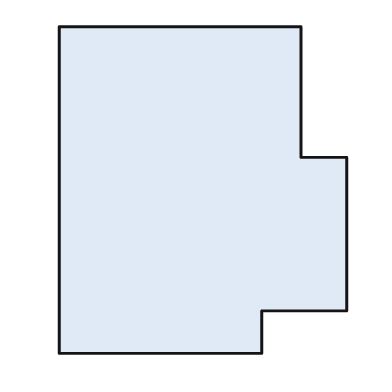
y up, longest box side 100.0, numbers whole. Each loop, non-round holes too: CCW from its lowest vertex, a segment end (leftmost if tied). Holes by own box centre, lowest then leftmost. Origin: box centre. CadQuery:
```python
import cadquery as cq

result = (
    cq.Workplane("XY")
    .moveTo(-44.0, -50.0)
    .lineTo(18.0, -50.0)
    .lineTo(18.0, -37.0)
    .lineTo(44.0, -37.0)
    .lineTo(44.0, 10.0)
    .lineTo(30.0, 10.0)
    .lineTo(30.0, 50.0)
    .lineTo(-44.0, 50.0)
    .close()
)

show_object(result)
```